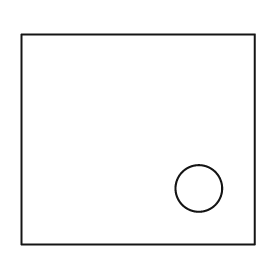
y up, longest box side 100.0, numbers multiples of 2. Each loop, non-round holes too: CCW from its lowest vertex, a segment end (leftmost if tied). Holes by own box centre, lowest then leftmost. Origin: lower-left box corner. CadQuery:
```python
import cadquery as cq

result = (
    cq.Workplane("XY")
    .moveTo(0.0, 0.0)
    .lineTo(100.0, 0.0)
    .lineTo(100.0, 90.0)
    .lineTo(0.0, 90.0)
    .close()
    .moveTo(76.0, 24.0)
    .circle(10.0)
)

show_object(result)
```